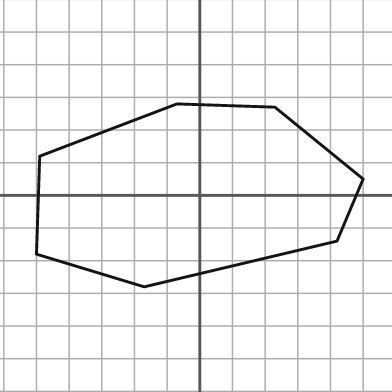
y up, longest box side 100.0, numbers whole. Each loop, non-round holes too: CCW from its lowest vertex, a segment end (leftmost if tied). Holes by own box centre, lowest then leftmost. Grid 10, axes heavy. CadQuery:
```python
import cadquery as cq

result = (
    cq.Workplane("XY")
    .moveTo(-17.0, -28.0)
    .lineTo(42.0, -14.0)
    .lineTo(50.0, 5.0)
    .lineTo(23.0, 27.0)
    .lineTo(-7.0, 28.0)
    .lineTo(-49.0, 12.0)
    .lineTo(-50.0, -18.0)
    .close()
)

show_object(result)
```